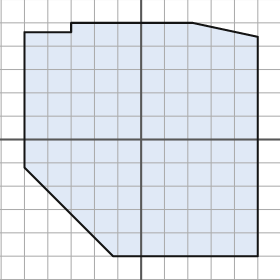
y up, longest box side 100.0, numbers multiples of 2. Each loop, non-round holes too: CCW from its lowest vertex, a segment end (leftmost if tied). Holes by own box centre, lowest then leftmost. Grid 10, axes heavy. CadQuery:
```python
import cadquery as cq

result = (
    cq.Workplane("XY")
    .moveTo(-12.0, -50.0)
    .lineTo(50.0, -50.0)
    .lineTo(50.0, 44.0)
    .lineTo(22.0, 50.0)
    .lineTo(-30.0, 50.0)
    .lineTo(-30.0, 46.0)
    .lineTo(-50.0, 46.0)
    .lineTo(-50.0, -12.0)
    .close()
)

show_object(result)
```